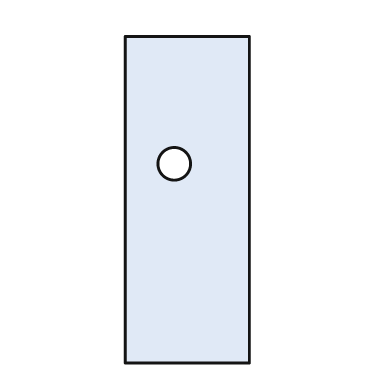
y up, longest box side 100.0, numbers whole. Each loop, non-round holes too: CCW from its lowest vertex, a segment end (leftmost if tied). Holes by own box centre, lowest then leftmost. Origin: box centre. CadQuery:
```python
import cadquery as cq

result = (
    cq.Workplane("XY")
    .moveTo(-19.0, -50.0)
    .lineTo(19.0, -50.0)
    .lineTo(19.0, 50.0)
    .lineTo(-19.0, 50.0)
    .close()
    .moveTo(-4.0, 11.0)
    .circle(5.0)
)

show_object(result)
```